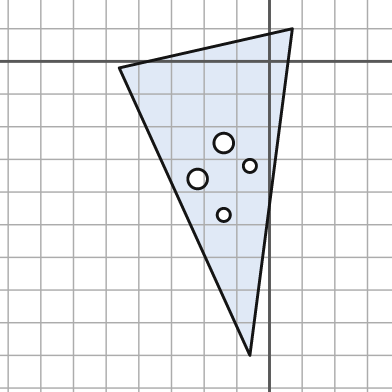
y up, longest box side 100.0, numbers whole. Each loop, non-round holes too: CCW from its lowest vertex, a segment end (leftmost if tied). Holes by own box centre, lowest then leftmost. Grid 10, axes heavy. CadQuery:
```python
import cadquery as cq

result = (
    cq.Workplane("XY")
    .moveTo(-6.0, -90.0)
    .lineTo(7.0, 10.0)
    .lineTo(-46.0, -2.0)
    .close()
    .moveTo(-14.0, -47.0)
    .circle(2.0)
    .moveTo(-22.0, -36.0)
    .circle(3.0)
    .moveTo(-6.0, -32.0)
    .circle(2.0)
    .moveTo(-14.0, -25.0)
    .circle(3.0)
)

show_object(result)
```